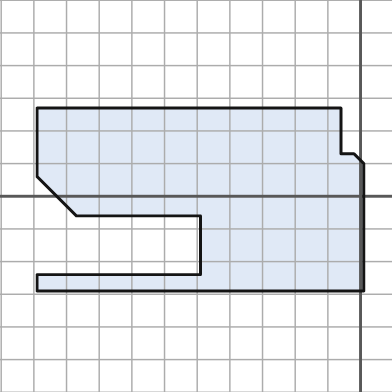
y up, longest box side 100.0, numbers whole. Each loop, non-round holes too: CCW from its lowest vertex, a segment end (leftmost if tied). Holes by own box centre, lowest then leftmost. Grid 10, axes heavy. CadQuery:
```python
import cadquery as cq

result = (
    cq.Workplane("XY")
    .moveTo(-99.0, -29.0)
    .lineTo(1.0, -29.0)
    .lineTo(1.0, 10.0)
    .lineTo(-2.0, 13.0)
    .lineTo(-6.0, 13.0)
    .lineTo(-6.0, 27.0)
    .lineTo(-99.0, 27.0)
    .lineTo(-99.0, 6.0)
    .lineTo(-87.0, -6.0)
    .lineTo(-49.0, -6.0)
    .lineTo(-49.0, -24.0)
    .lineTo(-99.0, -24.0)
    .close()
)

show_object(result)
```